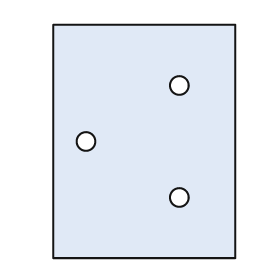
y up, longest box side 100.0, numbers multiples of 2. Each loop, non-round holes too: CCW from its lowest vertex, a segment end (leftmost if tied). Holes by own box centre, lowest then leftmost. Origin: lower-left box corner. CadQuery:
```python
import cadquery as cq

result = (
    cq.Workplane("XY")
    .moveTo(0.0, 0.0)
    .lineTo(78.0, 0.0)
    .lineTo(78.0, 100.0)
    .lineTo(0.0, 100.0)
    .close()
    .moveTo(54.0, 26.0)
    .circle(4.0)
    .moveTo(14.0, 50.0)
    .circle(4.0)
    .moveTo(54.0, 74.0)
    .circle(4.0)
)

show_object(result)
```